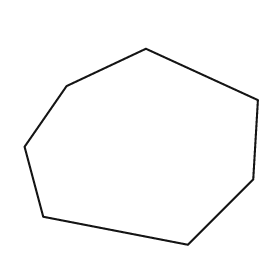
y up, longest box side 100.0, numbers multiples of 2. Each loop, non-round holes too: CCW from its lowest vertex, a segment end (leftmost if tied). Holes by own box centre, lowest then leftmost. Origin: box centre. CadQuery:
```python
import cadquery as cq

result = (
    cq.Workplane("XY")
    .moveTo(20.0, -42.0)
    .lineTo(48.0, -14.0)
    .lineTo(50.0, 20.0)
    .lineTo(2.0, 42.0)
    .lineTo(-32.0, 26.0)
    .lineTo(-50.0, 0.0)
    .lineTo(-42.0, -30.0)
    .close()
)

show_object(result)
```